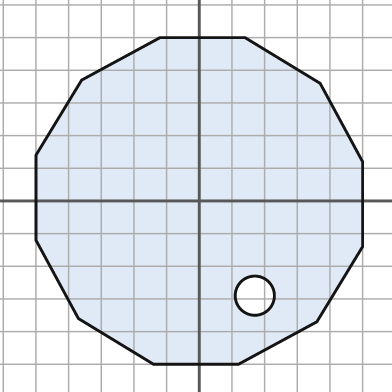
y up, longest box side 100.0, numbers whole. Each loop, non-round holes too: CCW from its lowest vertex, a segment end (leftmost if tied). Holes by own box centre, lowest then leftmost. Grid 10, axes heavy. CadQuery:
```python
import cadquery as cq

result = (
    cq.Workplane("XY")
    .moveTo(-14.0, -50.0)
    .lineTo(12.0, -50.0)
    .lineTo(36.0, -37.0)
    .lineTo(50.0, -14.0)
    .lineTo(50.0, 12.0)
    .lineTo(37.0, 36.0)
    .lineTo(14.0, 50.0)
    .lineTo(-12.0, 50.0)
    .lineTo(-36.0, 37.0)
    .lineTo(-50.0, 14.0)
    .lineTo(-50.0, -12.0)
    .lineTo(-37.0, -36.0)
    .close()
    .moveTo(17.0, -29.0)
    .circle(6.0)
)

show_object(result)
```